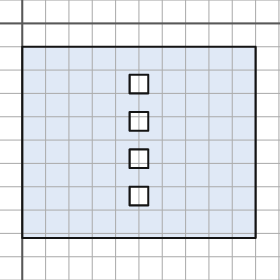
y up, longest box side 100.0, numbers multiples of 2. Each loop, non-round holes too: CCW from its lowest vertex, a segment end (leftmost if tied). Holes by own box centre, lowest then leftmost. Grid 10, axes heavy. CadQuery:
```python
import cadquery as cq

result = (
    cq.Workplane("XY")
    .moveTo(0.0, -92.0)
    .lineTo(100.0, -92.0)
    .lineTo(100.0, -10.0)
    .lineTo(0.0, -10.0)
    .close()
    .moveTo(46.0, -78.0)
    .lineTo(54.0, -78.0)
    .lineTo(54.0, -70.0)
    .lineTo(46.0, -70.0)
    .close()
    .moveTo(46.0, -62.0)
    .lineTo(54.0, -62.0)
    .lineTo(54.0, -54.0)
    .lineTo(46.0, -54.0)
    .close()
    .moveTo(46.0, -46.0)
    .lineTo(54.0, -46.0)
    .lineTo(54.0, -38.0)
    .lineTo(46.0, -38.0)
    .close()
    .moveTo(46.0, -30.0)
    .lineTo(54.0, -30.0)
    .lineTo(54.0, -22.0)
    .lineTo(46.0, -22.0)
    .close()
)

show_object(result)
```